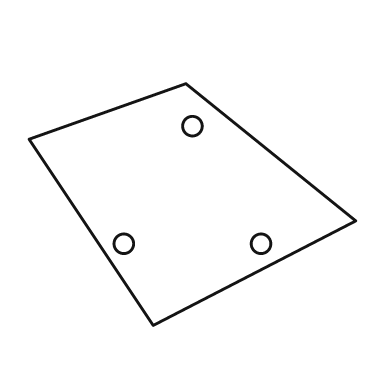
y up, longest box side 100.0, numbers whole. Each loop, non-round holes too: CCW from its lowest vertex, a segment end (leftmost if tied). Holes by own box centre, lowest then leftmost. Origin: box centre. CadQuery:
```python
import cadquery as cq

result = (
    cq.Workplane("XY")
    .moveTo(-12.0, -37.0)
    .lineTo(50.0, -5.0)
    .lineTo(-2.0, 37.0)
    .lineTo(-50.0, 20.0)
    .close()
    .moveTo(-21.0, -12.0)
    .circle(3.0)
    .moveTo(21.0, -12.0)
    .circle(3.0)
    .moveTo(0.0, 24.0)
    .circle(3.0)
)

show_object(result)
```